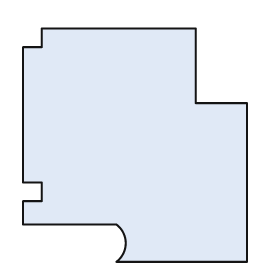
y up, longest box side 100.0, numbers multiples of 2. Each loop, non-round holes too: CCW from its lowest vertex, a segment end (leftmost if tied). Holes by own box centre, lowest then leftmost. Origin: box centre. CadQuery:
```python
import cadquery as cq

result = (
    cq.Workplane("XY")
    .moveTo(-8.0, -50.0)
    .lineTo(48.0, -50.0)
    .lineTo(48.0, 18.0)
    .lineTo(26.0, 18.0)
    .lineTo(26.0, 50.0)
    .lineTo(-40.0, 50.0)
    .lineTo(-40.0, 42.0)
    .lineTo(-48.0, 42.0)
    .lineTo(-48.0, -16.0)
    .lineTo(-40.0, -16.0)
    .lineTo(-40.0, -24.0)
    .lineTo(-48.0, -24.0)
    .lineTo(-48.0, -34.0)
    .lineTo(-8.0, -34.0)
    .threePointArc((-4.0, -42.0), (-8.0, -50.0))
    .close()
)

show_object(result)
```